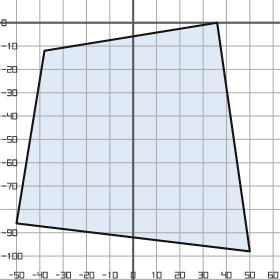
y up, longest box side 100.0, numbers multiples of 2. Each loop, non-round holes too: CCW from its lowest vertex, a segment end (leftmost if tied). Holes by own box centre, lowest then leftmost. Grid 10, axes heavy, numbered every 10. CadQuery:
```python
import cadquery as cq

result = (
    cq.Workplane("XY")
    .moveTo(50.0, -98.0)
    .lineTo(36.0, 0.0)
    .lineTo(-38.0, -12.0)
    .lineTo(-50.0, -86.0)
    .close()
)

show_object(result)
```